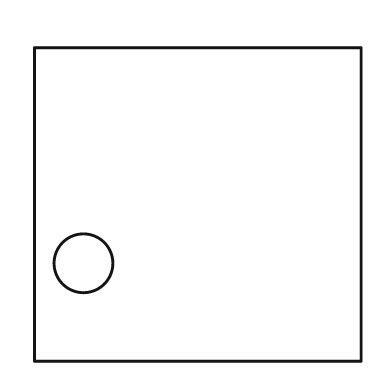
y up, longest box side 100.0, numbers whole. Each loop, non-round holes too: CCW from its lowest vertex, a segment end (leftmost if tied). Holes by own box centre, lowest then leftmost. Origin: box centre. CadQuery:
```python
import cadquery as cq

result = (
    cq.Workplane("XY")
    .moveTo(-50.0, -48.0)
    .lineTo(50.0, -48.0)
    .lineTo(50.0, 48.0)
    .lineTo(-50.0, 48.0)
    .close()
    .moveTo(-35.0, -18.0)
    .circle(9.0)
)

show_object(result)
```